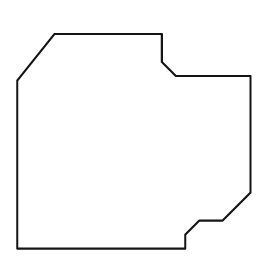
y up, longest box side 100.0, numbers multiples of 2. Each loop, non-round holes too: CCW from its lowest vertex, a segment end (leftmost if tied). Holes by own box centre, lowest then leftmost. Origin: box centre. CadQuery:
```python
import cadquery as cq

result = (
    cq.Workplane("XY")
    .moveTo(-50.0, -46.0)
    .lineTo(22.0, -46.0)
    .lineTo(22.0, -40.0)
    .lineTo(28.0, -34.0)
    .lineTo(38.0, -34.0)
    .lineTo(50.0, -22.0)
    .lineTo(50.0, 28.0)
    .lineTo(18.0, 28.0)
    .lineTo(12.0, 34.0)
    .lineTo(12.0, 46.0)
    .lineTo(-34.0, 46.0)
    .lineTo(-50.0, 26.0)
    .close()
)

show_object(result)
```